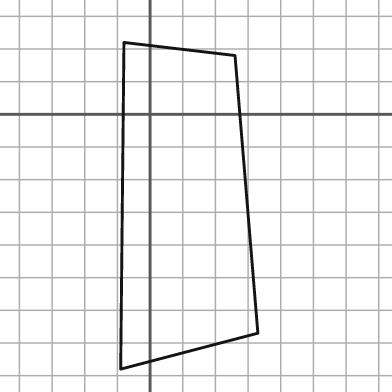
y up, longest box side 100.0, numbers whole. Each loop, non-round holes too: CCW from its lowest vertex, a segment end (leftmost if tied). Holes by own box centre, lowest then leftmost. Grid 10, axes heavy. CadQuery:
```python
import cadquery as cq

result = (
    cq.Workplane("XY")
    .moveTo(-9.0, -78.0)
    .lineTo(33.0, -67.0)
    .lineTo(26.0, 18.0)
    .lineTo(-8.0, 22.0)
    .close()
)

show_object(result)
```